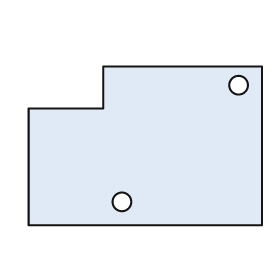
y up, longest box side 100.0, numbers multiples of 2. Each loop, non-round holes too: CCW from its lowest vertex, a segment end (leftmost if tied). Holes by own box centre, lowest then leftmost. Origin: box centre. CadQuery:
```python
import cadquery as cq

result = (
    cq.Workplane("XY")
    .moveTo(-50.0, -34.0)
    .lineTo(50.0, -34.0)
    .lineTo(50.0, 34.0)
    .lineTo(-18.0, 34.0)
    .lineTo(-18.0, 16.0)
    .lineTo(-50.0, 16.0)
    .close()
    .moveTo(-10.0, -24.0)
    .circle(4.0)
    .moveTo(40.0, 26.0)
    .circle(4.0)
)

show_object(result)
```